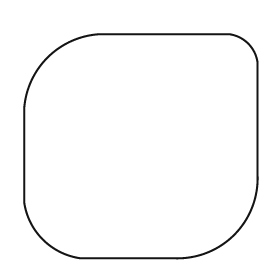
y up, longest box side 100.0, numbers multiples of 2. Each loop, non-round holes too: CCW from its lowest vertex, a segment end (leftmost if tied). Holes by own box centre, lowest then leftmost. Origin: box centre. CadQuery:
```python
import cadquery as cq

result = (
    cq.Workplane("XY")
    .moveTo(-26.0, -48.0)
    .lineTo(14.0, -48.0)
    .threePointArc((40.0, -38.0), (50.0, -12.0))
    .lineTo(50.0, 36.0)
    .threePointArc((46.0, 44.0), (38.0, 48.0))
    .lineTo(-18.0, 48.0)
    .threePointArc((-40.0, 38.0), (-50.0, 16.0))
    .lineTo(-50.0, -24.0)
    .threePointArc((-42.0, -40.0), (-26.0, -48.0))
    .close()
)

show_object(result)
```